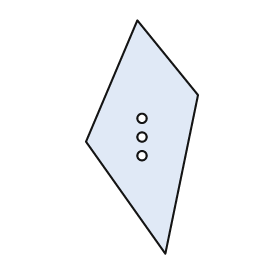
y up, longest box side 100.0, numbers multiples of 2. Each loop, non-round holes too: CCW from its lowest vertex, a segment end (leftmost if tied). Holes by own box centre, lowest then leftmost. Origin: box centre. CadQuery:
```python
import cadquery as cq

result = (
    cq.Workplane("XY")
    .moveTo(10.0, -50.0)
    .lineTo(24.0, 18.0)
    .lineTo(-2.0, 50.0)
    .lineTo(-24.0, -2.0)
    .close()
    .moveTo(0.0, -8.0)
    .circle(2.0)
    .moveTo(0.0, 0.0)
    .circle(2.0)
    .moveTo(0.0, 8.0)
    .circle(2.0)
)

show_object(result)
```